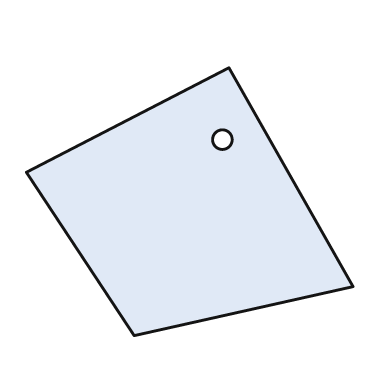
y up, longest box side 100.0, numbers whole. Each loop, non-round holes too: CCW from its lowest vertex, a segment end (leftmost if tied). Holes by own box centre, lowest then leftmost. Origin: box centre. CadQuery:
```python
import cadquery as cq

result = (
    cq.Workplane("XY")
    .moveTo(-17.0, -41.0)
    .lineTo(50.0, -26.0)
    .lineTo(12.0, 41.0)
    .lineTo(-50.0, 9.0)
    .close()
    .moveTo(10.0, 19.0)
    .circle(3.0)
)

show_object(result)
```